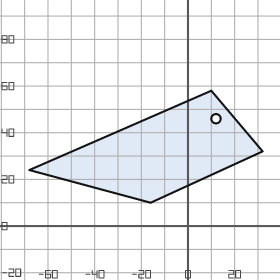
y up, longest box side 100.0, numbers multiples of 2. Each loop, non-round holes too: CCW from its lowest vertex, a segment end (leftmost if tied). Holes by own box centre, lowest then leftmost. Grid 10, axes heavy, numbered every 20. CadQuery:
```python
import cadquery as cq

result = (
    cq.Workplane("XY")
    .moveTo(-16.0, 10.0)
    .lineTo(32.0, 32.0)
    .lineTo(10.0, 58.0)
    .lineTo(-68.0, 24.0)
    .close()
    .moveTo(12.0, 46.0)
    .circle(2.0)
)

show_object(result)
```